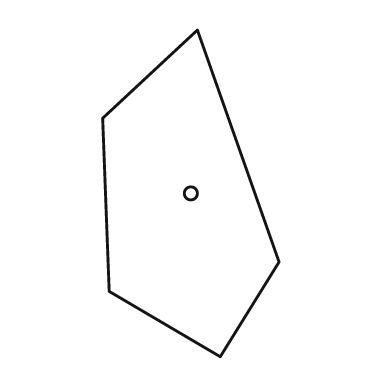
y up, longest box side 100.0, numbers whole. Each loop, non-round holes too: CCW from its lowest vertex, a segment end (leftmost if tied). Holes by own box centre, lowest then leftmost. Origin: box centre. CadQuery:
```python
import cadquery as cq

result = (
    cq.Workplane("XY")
    .moveTo(9.0, -50.0)
    .lineTo(27.0, -21.0)
    .lineTo(2.0, 50.0)
    .lineTo(-27.0, 23.0)
    .lineTo(-25.0, -30.0)
    .close()
    .moveTo(0.0, 0.0)
    .circle(2.0)
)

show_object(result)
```